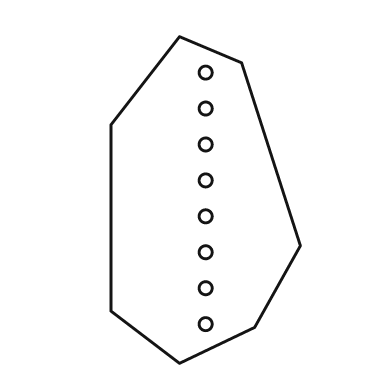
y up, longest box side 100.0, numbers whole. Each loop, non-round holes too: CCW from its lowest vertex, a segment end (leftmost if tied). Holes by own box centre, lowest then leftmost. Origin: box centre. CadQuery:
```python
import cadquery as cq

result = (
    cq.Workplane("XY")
    .moveTo(-8.0, -50.0)
    .lineTo(15.0, -39.0)
    .lineTo(29.0, -14.0)
    .lineTo(11.0, 42.0)
    .lineTo(-8.0, 50.0)
    .lineTo(-29.0, 23.0)
    .lineTo(-29.0, -34.0)
    .close()
    .moveTo(0.0, -38.0)
    .circle(2.0)
    .moveTo(0.0, -27.0)
    .circle(2.0)
    .moveTo(0.0, -16.0)
    .circle(2.0)
    .moveTo(0.0, -5.0)
    .circle(2.0)
    .moveTo(0.0, 6.0)
    .circle(2.0)
    .moveTo(0.0, 17.0)
    .circle(2.0)
    .moveTo(0.0, 28.0)
    .circle(2.0)
    .moveTo(0.0, 39.0)
    .circle(2.0)
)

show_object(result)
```